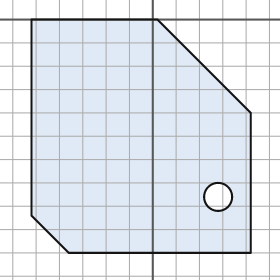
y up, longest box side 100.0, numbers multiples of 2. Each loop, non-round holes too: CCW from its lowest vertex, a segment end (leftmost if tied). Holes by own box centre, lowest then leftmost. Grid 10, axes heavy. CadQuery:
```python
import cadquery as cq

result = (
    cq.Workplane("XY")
    .moveTo(-36.0, -100.0)
    .lineTo(42.0, -100.0)
    .lineTo(42.0, -40.0)
    .lineTo(2.0, 0.0)
    .lineTo(-52.0, 0.0)
    .lineTo(-52.0, -84.0)
    .close()
    .moveTo(28.0, -76.0)
    .circle(6.0)
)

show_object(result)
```